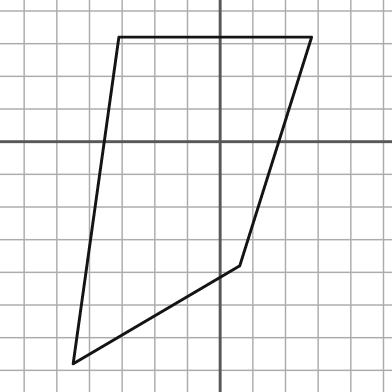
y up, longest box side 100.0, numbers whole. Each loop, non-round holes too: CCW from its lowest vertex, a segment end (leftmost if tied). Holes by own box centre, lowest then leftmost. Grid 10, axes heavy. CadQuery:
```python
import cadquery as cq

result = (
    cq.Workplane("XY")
    .moveTo(-45.0, -68.0)
    .lineTo(6.0, -38.0)
    .lineTo(28.0, 32.0)
    .lineTo(-31.0, 32.0)
    .close()
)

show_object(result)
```